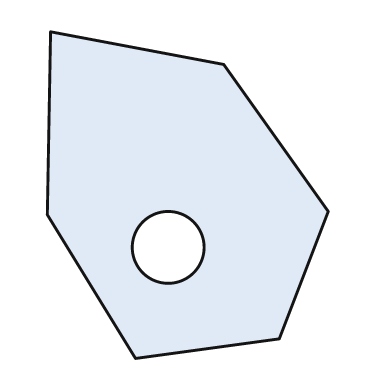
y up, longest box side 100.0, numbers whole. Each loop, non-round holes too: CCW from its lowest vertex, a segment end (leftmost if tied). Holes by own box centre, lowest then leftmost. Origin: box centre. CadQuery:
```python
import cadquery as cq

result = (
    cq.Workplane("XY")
    .moveTo(-16.0, -50.0)
    .lineTo(28.0, -44.0)
    .lineTo(43.0, -5.0)
    .lineTo(11.0, 40.0)
    .lineTo(-42.0, 50.0)
    .lineTo(-43.0, -6.0)
    .close()
    .moveTo(-6.0, -16.0)
    .circle(11.0)
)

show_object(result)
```